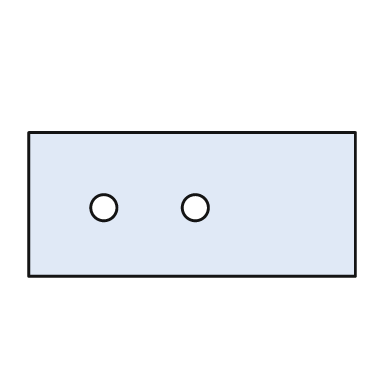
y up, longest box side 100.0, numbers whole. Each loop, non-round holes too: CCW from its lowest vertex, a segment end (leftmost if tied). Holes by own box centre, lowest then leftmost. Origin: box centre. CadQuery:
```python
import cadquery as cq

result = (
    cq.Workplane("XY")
    .moveTo(-50.0, -22.0)
    .lineTo(50.0, -22.0)
    .lineTo(50.0, 22.0)
    .lineTo(-50.0, 22.0)
    .close()
    .moveTo(-27.0, -1.0)
    .circle(4.0)
    .moveTo(1.0, -1.0)
    .circle(4.0)
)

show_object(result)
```